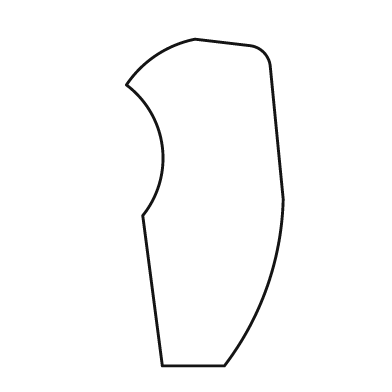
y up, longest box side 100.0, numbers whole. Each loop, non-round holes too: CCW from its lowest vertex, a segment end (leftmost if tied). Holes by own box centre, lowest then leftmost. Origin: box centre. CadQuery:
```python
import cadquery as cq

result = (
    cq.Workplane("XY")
    .moveTo(-13.0, -50.0)
    .lineTo(6.0, -50.0)
    .threePointArc((19.0, -26.0), (24.0, 1.0))
    .lineTo(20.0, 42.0)
    .threePointArc((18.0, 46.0), (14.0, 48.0))
    .lineTo(-3.0, 50.0)
    .threePointArc((-15.0, 45.0), (-24.0, 36.0))
    .threePointArc((-13.0, 17.0), (-19.0, -4.0))
    .close()
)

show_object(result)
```